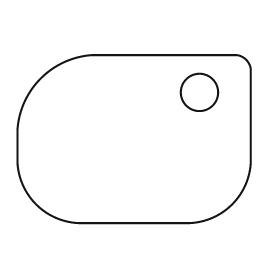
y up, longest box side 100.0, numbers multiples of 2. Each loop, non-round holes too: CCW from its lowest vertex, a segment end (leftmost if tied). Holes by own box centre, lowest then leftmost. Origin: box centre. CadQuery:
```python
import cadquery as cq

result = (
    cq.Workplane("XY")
    .moveTo(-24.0, -36.0)
    .lineTo(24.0, -36.0)
    .threePointArc((42.0, -28.0), (50.0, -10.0))
    .lineTo(50.0, 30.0)
    .threePointArc((48.0, 34.0), (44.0, 36.0))
    .lineTo(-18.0, 36.0)
    .threePointArc((-40.0, 26.0), (-50.0, 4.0))
    .lineTo(-50.0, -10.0)
    .threePointArc((-42.0, -28.0), (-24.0, -36.0))
    .close()
    .moveTo(28.0, 20.0)
    .circle(8.0)
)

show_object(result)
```